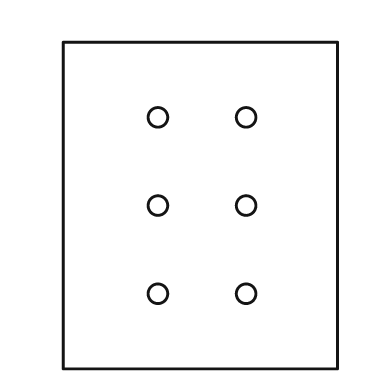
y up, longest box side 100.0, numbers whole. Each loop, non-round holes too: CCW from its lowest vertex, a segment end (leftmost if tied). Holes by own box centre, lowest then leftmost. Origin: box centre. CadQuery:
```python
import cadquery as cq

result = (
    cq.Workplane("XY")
    .moveTo(-42.0, -50.0)
    .lineTo(42.0, -50.0)
    .lineTo(42.0, 50.0)
    .lineTo(-42.0, 50.0)
    .close()
    .moveTo(-13.0, -27.0)
    .circle(3.0)
    .moveTo(14.0, -27.0)
    .circle(3.0)
    .moveTo(-13.0, 0.0)
    .circle(3.0)
    .moveTo(14.0, 0.0)
    .circle(3.0)
    .moveTo(-13.0, 27.0)
    .circle(3.0)
    .moveTo(14.0, 27.0)
    .circle(3.0)
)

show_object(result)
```